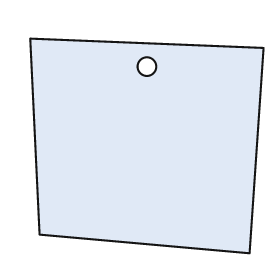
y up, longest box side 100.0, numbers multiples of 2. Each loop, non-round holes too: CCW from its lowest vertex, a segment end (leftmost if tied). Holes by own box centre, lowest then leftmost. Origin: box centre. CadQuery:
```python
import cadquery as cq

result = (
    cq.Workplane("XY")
    .moveTo(44.0, -46.0)
    .lineTo(50.0, 42.0)
    .lineTo(-50.0, 46.0)
    .lineTo(-46.0, -38.0)
    .close()
    .moveTo(0.0, 34.0)
    .circle(4.0)
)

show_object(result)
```